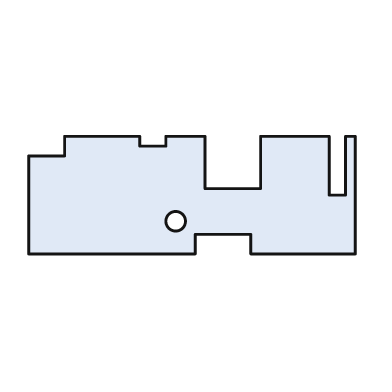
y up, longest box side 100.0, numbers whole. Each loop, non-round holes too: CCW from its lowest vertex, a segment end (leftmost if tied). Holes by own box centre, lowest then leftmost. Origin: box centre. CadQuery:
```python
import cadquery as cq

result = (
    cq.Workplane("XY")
    .moveTo(-50.0, -18.0)
    .lineTo(1.0, -18.0)
    .lineTo(1.0, -12.0)
    .lineTo(18.0, -12.0)
    .lineTo(18.0, -18.0)
    .lineTo(50.0, -18.0)
    .lineTo(50.0, 18.0)
    .lineTo(47.0, 18.0)
    .lineTo(47.0, 0.0)
    .lineTo(42.0, 0.0)
    .lineTo(42.0, 18.0)
    .lineTo(21.0, 18.0)
    .lineTo(21.0, 2.0)
    .lineTo(4.0, 2.0)
    .lineTo(4.0, 18.0)
    .lineTo(-8.0, 18.0)
    .lineTo(-8.0, 15.0)
    .lineTo(-16.0, 15.0)
    .lineTo(-16.0, 18.0)
    .lineTo(-39.0, 18.0)
    .lineTo(-39.0, 12.0)
    .lineTo(-50.0, 12.0)
    .close()
    .moveTo(-5.0, -8.0)
    .circle(3.0)
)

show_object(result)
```